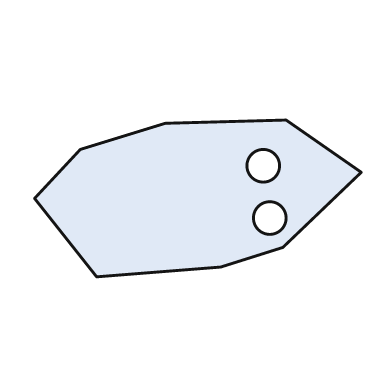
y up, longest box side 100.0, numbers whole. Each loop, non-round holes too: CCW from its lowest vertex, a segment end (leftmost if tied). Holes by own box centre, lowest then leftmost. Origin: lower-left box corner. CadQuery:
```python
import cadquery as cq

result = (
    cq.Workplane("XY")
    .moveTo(19.0, 0.0)
    .lineTo(57.0, 3.0)
    .lineTo(76.0, 9.0)
    .lineTo(100.0, 32.0)
    .lineTo(77.0, 48.0)
    .lineTo(40.0, 47.0)
    .lineTo(14.0, 39.0)
    .lineTo(0.0, 24.0)
    .close()
    .moveTo(72.0, 18.0)
    .circle(5.0)
    .moveTo(70.0, 34.0)
    .circle(5.0)
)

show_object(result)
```